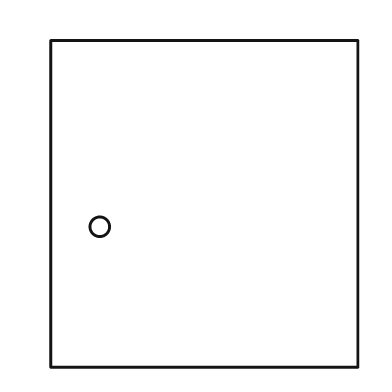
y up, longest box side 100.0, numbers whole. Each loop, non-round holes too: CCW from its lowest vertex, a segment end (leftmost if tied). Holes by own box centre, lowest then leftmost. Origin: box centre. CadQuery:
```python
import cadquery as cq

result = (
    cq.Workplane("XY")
    .moveTo(-47.0, -50.0)
    .lineTo(47.0, -50.0)
    .lineTo(47.0, 50.0)
    .lineTo(-47.0, 50.0)
    .close()
    .moveTo(-32.0, -7.0)
    .circle(3.0)
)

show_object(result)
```